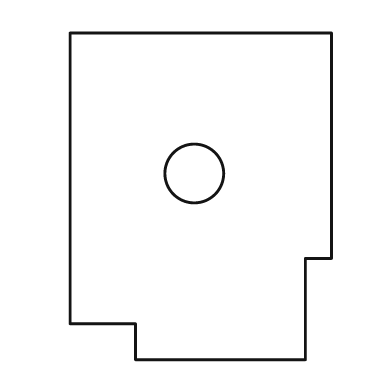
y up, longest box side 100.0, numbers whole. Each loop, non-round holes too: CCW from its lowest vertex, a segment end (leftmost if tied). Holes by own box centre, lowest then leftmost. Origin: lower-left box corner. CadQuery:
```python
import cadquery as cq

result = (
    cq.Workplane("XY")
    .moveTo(20.0, 0.0)
    .lineTo(72.0, 0.0)
    .lineTo(72.0, 31.0)
    .lineTo(80.0, 31.0)
    .lineTo(80.0, 100.0)
    .lineTo(0.0, 100.0)
    .lineTo(0.0, 11.0)
    .lineTo(20.0, 11.0)
    .close()
    .moveTo(38.0, 57.0)
    .circle(9.0)
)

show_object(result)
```